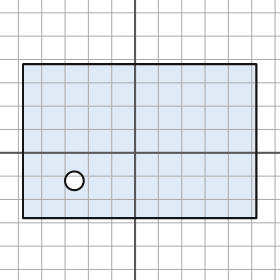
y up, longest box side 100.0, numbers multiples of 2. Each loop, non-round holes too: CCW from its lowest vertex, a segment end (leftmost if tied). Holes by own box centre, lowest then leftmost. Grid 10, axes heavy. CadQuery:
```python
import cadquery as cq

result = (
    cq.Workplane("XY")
    .moveTo(-48.0, -28.0)
    .lineTo(52.0, -28.0)
    .lineTo(52.0, 38.0)
    .lineTo(-48.0, 38.0)
    .close()
    .moveTo(-26.0, -12.0)
    .circle(4.0)
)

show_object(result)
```